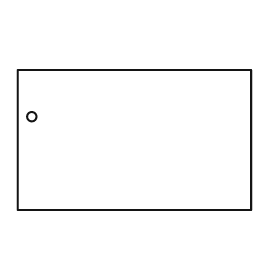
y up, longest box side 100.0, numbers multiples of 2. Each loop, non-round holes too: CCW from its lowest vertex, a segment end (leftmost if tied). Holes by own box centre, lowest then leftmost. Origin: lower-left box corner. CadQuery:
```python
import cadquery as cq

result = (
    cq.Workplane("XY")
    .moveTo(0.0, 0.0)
    .lineTo(100.0, 0.0)
    .lineTo(100.0, 60.0)
    .lineTo(0.0, 60.0)
    .close()
    .moveTo(6.0, 40.0)
    .circle(2.0)
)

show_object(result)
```